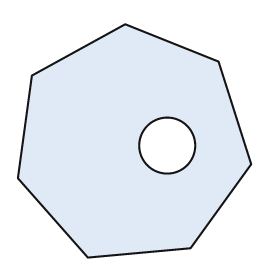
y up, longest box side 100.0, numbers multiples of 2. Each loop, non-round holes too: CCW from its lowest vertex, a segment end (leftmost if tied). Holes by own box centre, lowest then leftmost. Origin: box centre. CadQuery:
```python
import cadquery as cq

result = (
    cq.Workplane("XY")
    .moveTo(-20.0, -50.0)
    .lineTo(24.0, -46.0)
    .lineTo(50.0, -10.0)
    .lineTo(36.0, 34.0)
    .lineTo(-4.0, 50.0)
    .lineTo(-44.0, 28.0)
    .lineTo(-50.0, -16.0)
    .close()
    .moveTo(14.0, -2.0)
    .circle(12.0)
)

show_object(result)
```